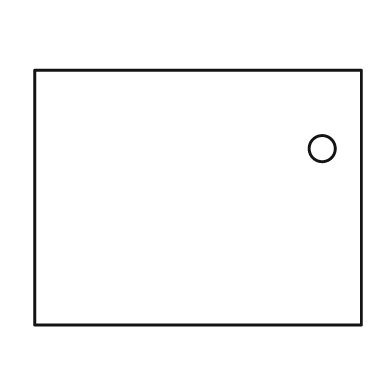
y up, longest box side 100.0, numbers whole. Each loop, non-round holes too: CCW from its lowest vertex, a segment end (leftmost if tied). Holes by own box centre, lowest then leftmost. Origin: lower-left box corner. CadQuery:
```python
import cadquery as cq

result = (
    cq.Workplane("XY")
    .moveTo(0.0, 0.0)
    .lineTo(100.0, 0.0)
    .lineTo(100.0, 78.0)
    .lineTo(0.0, 78.0)
    .close()
    .moveTo(88.0, 54.0)
    .circle(4.0)
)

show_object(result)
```